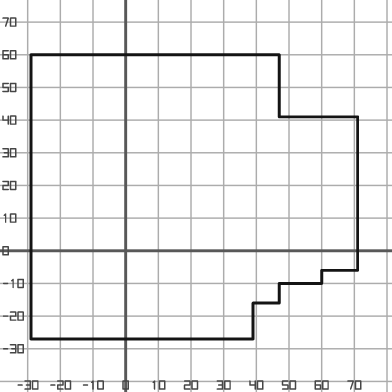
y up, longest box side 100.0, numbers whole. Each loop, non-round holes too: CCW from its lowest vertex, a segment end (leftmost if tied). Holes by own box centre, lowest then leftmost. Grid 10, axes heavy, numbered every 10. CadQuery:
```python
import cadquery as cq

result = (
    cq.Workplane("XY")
    .moveTo(-29.0, -27.0)
    .lineTo(39.0, -27.0)
    .lineTo(39.0, -16.0)
    .lineTo(47.0, -16.0)
    .lineTo(47.0, -10.0)
    .lineTo(60.0, -10.0)
    .lineTo(60.0, -6.0)
    .lineTo(71.0, -6.0)
    .lineTo(71.0, 41.0)
    .lineTo(47.0, 41.0)
    .lineTo(47.0, 60.0)
    .lineTo(-29.0, 60.0)
    .close()
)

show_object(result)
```